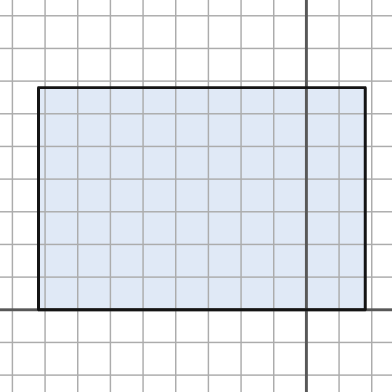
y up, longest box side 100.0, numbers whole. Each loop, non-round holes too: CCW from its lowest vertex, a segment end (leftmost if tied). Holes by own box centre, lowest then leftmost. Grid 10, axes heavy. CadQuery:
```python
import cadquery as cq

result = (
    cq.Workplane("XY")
    .moveTo(-82.0, 0.0)
    .lineTo(18.0, 0.0)
    .lineTo(18.0, 68.0)
    .lineTo(-82.0, 68.0)
    .close()
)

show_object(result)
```